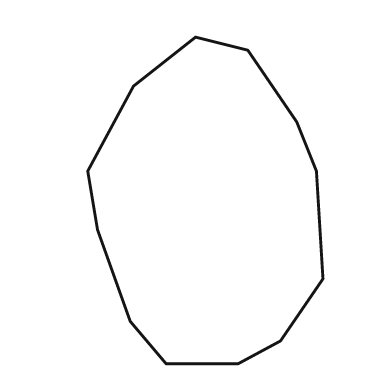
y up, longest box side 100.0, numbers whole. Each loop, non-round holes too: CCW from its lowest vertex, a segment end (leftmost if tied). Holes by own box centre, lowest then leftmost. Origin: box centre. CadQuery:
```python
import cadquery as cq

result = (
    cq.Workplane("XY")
    .moveTo(-12.0, -50.0)
    .lineTo(10.0, -50.0)
    .lineTo(23.0, -43.0)
    .lineTo(36.0, -24.0)
    .lineTo(34.0, 9.0)
    .lineTo(28.0, 24.0)
    .lineTo(13.0, 46.0)
    .lineTo(-3.0, 50.0)
    .lineTo(-22.0, 35.0)
    .lineTo(-36.0, 9.0)
    .lineTo(-33.0, -9.0)
    .lineTo(-23.0, -37.0)
    .close()
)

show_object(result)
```